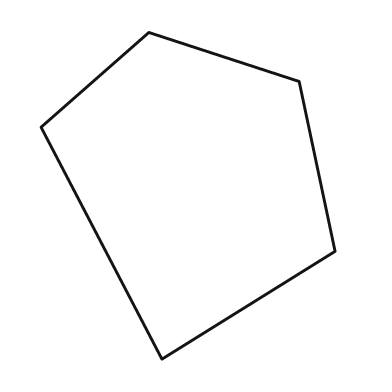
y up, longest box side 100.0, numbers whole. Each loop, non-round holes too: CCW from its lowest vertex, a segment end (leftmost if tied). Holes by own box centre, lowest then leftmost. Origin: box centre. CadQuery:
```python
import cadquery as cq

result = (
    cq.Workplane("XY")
    .moveTo(-8.0, -50.0)
    .lineTo(45.0, -17.0)
    .lineTo(34.0, 35.0)
    .lineTo(-12.0, 50.0)
    .lineTo(-45.0, 21.0)
    .close()
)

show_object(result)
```